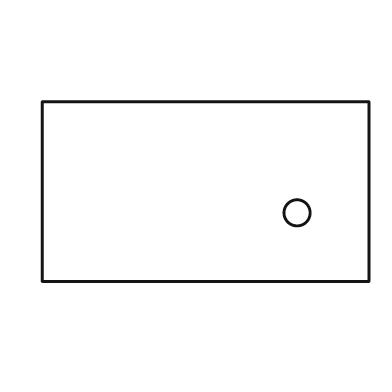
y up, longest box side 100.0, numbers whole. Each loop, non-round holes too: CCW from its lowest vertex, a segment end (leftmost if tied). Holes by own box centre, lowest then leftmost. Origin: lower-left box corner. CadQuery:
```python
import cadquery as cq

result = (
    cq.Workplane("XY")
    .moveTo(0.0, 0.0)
    .lineTo(100.0, 0.0)
    .lineTo(100.0, 55.0)
    .lineTo(0.0, 55.0)
    .close()
    .moveTo(78.0, 21.0)
    .circle(4.0)
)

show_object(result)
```